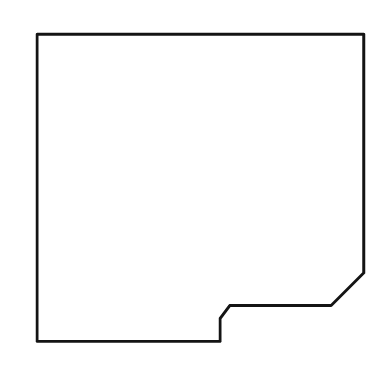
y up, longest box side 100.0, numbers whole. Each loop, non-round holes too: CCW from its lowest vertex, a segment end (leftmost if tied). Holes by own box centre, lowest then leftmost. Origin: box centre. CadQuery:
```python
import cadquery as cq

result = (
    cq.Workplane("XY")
    .moveTo(-50.0, -47.0)
    .lineTo(6.0, -47.0)
    .lineTo(6.0, -40.0)
    .lineTo(9.0, -36.0)
    .lineTo(40.0, -36.0)
    .lineTo(50.0, -26.0)
    .lineTo(50.0, 47.0)
    .lineTo(-50.0, 47.0)
    .close()
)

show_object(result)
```